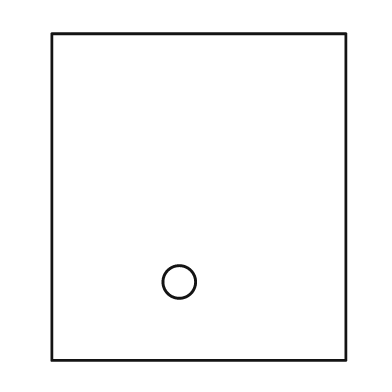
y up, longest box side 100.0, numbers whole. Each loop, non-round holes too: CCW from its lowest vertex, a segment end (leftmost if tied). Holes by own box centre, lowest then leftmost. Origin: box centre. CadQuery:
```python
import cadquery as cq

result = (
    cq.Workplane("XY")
    .moveTo(-45.0, -50.0)
    .lineTo(45.0, -50.0)
    .lineTo(45.0, 50.0)
    .lineTo(-45.0, 50.0)
    .close()
    .moveTo(-6.0, -26.0)
    .circle(5.0)
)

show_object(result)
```